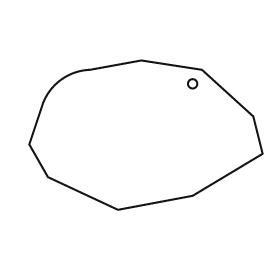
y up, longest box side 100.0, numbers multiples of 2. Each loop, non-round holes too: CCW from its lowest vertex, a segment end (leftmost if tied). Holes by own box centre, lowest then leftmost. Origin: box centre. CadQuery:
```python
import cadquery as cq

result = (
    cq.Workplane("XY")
    .moveTo(-12.0, -32.0)
    .lineTo(20.0, -26.0)
    .lineTo(50.0, -8.0)
    .lineTo(46.0, 8.0)
    .lineTo(24.0, 28.0)
    .lineTo(-2.0, 32.0)
    .lineTo(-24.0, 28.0)
    .threePointArc((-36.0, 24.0), (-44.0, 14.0))
    .lineTo(-50.0, -4.0)
    .lineTo(-42.0, -18.0)
    .close()
    .moveTo(20.0, 22.0)
    .circle(2.0)
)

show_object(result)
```